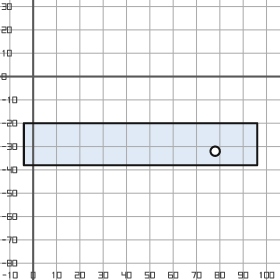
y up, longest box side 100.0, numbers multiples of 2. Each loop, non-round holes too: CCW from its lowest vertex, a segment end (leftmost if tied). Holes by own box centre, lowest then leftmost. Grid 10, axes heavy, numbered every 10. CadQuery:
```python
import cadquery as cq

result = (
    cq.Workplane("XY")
    .moveTo(-4.0, -38.0)
    .lineTo(96.0, -38.0)
    .lineTo(96.0, -20.0)
    .lineTo(-4.0, -20.0)
    .close()
    .moveTo(78.0, -32.0)
    .circle(2.0)
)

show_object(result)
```